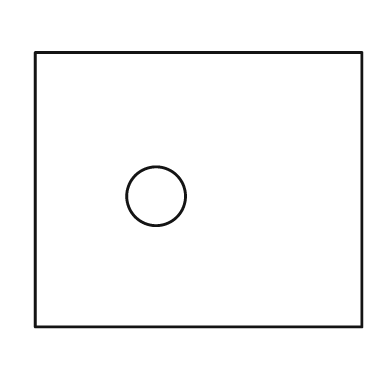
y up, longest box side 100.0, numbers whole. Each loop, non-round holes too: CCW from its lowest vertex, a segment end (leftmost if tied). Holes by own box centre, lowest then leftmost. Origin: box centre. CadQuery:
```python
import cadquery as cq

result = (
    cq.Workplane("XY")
    .moveTo(-50.0, -42.0)
    .lineTo(50.0, -42.0)
    .lineTo(50.0, 42.0)
    .lineTo(-50.0, 42.0)
    .close()
    .moveTo(-13.0, -2.0)
    .circle(9.0)
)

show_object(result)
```